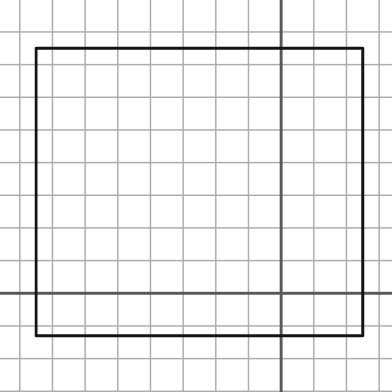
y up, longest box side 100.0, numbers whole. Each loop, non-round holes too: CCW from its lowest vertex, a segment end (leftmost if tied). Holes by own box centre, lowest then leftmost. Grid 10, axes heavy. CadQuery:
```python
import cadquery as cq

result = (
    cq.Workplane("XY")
    .moveTo(-75.0, -13.0)
    .lineTo(25.0, -13.0)
    .lineTo(25.0, 75.0)
    .lineTo(-75.0, 75.0)
    .close()
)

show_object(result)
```